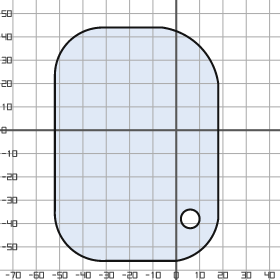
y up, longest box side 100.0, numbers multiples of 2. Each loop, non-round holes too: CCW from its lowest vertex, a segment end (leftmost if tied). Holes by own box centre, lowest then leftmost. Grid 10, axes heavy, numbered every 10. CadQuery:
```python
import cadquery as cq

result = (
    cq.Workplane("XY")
    .moveTo(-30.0, -56.0)
    .lineTo(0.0, -56.0)
    .threePointArc((12.0, -50.0), (18.0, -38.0))
    .lineTo(18.0, 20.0)
    .threePointArc((10.0, 36.0), (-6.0, 44.0))
    .lineTo(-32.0, 44.0)
    .threePointArc((-46.0, 38.0), (-52.0, 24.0))
    .lineTo(-52.0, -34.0)
    .threePointArc((-46.0, -50.0), (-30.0, -56.0))
    .close()
    .moveTo(6.0, -38.0)
    .circle(4.0)
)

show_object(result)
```